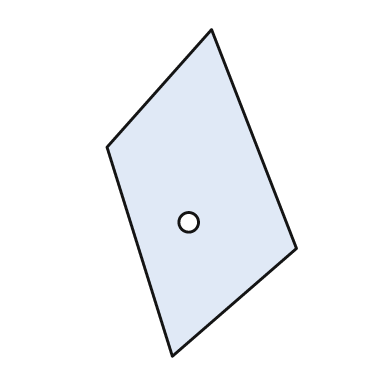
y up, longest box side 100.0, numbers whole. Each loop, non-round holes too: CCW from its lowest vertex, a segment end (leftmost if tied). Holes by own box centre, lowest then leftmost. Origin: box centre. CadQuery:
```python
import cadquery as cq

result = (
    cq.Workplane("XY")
    .moveTo(-9.0, -50.0)
    .lineTo(29.0, -17.0)
    .lineTo(3.0, 50.0)
    .lineTo(-29.0, 14.0)
    .close()
    .moveTo(-4.0, -9.0)
    .circle(3.0)
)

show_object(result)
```